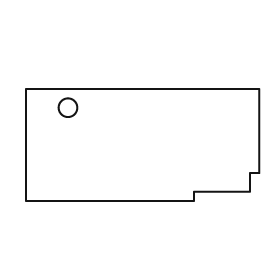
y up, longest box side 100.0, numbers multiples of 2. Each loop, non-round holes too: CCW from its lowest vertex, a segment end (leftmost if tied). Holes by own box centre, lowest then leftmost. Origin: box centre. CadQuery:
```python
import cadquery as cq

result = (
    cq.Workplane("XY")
    .moveTo(-50.0, -24.0)
    .lineTo(22.0, -24.0)
    .lineTo(22.0, -20.0)
    .lineTo(46.0, -20.0)
    .lineTo(46.0, -12.0)
    .lineTo(50.0, -12.0)
    .lineTo(50.0, 24.0)
    .lineTo(-50.0, 24.0)
    .close()
    .moveTo(-32.0, 16.0)
    .circle(4.0)
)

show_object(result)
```